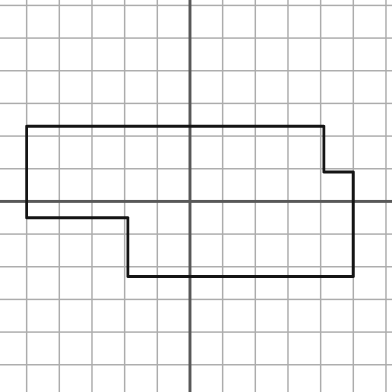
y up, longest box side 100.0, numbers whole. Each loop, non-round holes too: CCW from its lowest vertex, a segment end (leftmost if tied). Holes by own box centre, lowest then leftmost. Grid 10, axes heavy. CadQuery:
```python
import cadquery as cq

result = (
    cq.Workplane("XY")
    .moveTo(-19.0, -23.0)
    .lineTo(50.0, -23.0)
    .lineTo(50.0, 9.0)
    .lineTo(41.0, 9.0)
    .lineTo(41.0, 23.0)
    .lineTo(-50.0, 23.0)
    .lineTo(-50.0, -5.0)
    .lineTo(-19.0, -5.0)
    .close()
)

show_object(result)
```